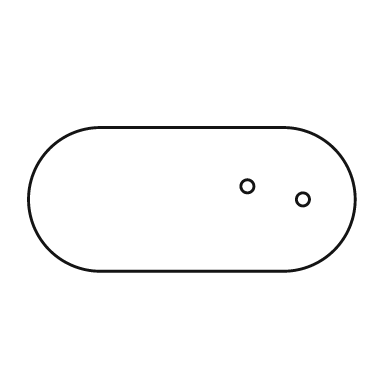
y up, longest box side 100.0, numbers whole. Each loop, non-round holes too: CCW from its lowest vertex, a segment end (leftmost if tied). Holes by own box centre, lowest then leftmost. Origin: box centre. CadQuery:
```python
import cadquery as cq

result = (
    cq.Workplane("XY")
    .moveTo(-28.0, -22.0)
    .lineTo(28.0, -22.0)
    .threePointArc((50.0, 0.0), (28.0, 22.0))
    .lineTo(-28.0, 22.0)
    .threePointArc((-50.0, 0.0), (-28.0, -22.0))
    .close()
    .moveTo(34.0, 0.0)
    .circle(2.0)
    .moveTo(17.0, 4.0)
    .circle(2.0)
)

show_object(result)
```